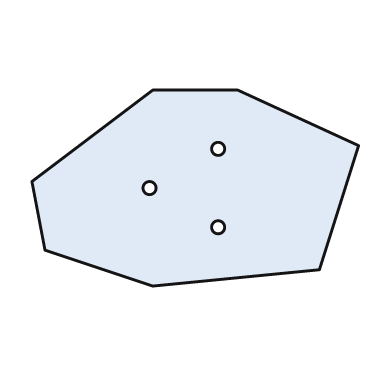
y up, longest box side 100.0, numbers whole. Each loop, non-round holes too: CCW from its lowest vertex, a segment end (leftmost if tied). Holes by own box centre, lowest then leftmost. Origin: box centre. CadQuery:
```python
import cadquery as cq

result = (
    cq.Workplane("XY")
    .moveTo(-13.0, -30.0)
    .lineTo(38.0, -25.0)
    .lineTo(50.0, 13.0)
    .lineTo(13.0, 30.0)
    .lineTo(-13.0, 30.0)
    .lineTo(-50.0, 2.0)
    .lineTo(-46.0, -19.0)
    .close()
    .moveTo(7.0, -12.0)
    .circle(2.0)
    .moveTo(-14.0, 0.0)
    .circle(2.0)
    .moveTo(7.0, 12.0)
    .circle(2.0)
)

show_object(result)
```